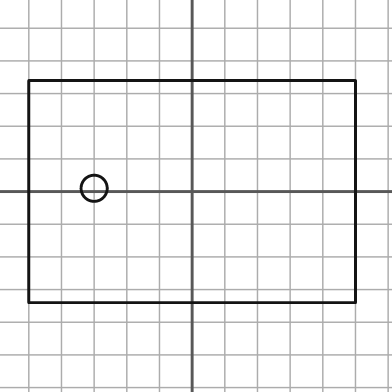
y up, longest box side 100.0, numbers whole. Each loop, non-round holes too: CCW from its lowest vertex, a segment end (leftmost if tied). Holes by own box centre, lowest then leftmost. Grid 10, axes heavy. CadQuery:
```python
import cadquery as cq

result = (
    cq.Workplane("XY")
    .moveTo(-50.0, -34.0)
    .lineTo(50.0, -34.0)
    .lineTo(50.0, 34.0)
    .lineTo(-50.0, 34.0)
    .close()
    .moveTo(-30.0, 1.0)
    .circle(4.0)
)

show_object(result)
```